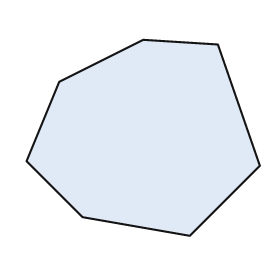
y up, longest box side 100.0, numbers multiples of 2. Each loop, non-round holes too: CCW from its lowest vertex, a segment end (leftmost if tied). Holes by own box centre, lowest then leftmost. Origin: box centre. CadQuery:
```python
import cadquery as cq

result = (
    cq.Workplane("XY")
    .moveTo(20.0, -42.0)
    .lineTo(50.0, -12.0)
    .lineTo(32.0, 40.0)
    .lineTo(0.0, 42.0)
    .lineTo(-36.0, 24.0)
    .lineTo(-50.0, -10.0)
    .lineTo(-26.0, -34.0)
    .close()
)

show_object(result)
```